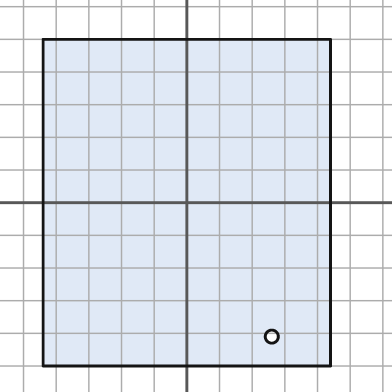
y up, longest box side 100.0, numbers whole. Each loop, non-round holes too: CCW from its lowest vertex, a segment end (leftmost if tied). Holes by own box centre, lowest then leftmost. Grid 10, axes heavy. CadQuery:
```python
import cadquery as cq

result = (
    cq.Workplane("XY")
    .moveTo(-44.0, -50.0)
    .lineTo(44.0, -50.0)
    .lineTo(44.0, 50.0)
    .lineTo(-44.0, 50.0)
    .close()
    .moveTo(26.0, -41.0)
    .circle(2.0)
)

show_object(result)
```